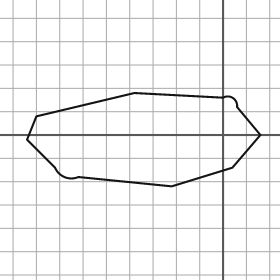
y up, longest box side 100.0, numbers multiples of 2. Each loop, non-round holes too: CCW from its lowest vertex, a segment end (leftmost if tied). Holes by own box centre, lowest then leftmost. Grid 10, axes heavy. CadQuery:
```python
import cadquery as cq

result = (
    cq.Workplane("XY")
    .moveTo(-22.0, -22.0)
    .lineTo(4.0, -14.0)
    .lineTo(16.0, 0.0)
    .lineTo(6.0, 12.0)
    .threePointArc((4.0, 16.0), (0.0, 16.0))
    .lineTo(-38.0, 18.0)
    .lineTo(-80.0, 8.0)
    .lineTo(-84.0, -2.0)
    .lineTo(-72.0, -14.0)
    .threePointArc((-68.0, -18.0), (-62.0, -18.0))
    .close()
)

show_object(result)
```